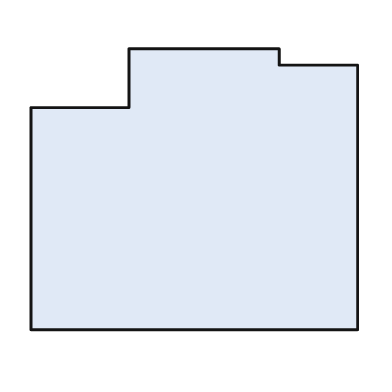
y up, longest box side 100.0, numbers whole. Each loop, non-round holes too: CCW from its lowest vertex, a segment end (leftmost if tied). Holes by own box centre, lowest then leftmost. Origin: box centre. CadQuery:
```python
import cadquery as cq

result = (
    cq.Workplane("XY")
    .moveTo(-50.0, -43.0)
    .lineTo(50.0, -43.0)
    .lineTo(50.0, 38.0)
    .lineTo(26.0, 38.0)
    .lineTo(26.0, 43.0)
    .lineTo(-20.0, 43.0)
    .lineTo(-20.0, 25.0)
    .lineTo(-50.0, 25.0)
    .close()
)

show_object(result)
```